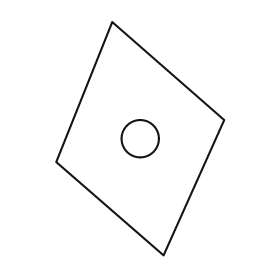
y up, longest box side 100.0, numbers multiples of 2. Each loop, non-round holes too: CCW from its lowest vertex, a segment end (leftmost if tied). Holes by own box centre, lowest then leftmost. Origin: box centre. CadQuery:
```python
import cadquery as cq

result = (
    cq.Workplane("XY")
    .moveTo(10.0, -50.0)
    .lineTo(36.0, 8.0)
    .lineTo(-12.0, 50.0)
    .lineTo(-36.0, -10.0)
    .close()
    .moveTo(0.0, 0.0)
    .circle(8.0)
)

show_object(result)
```